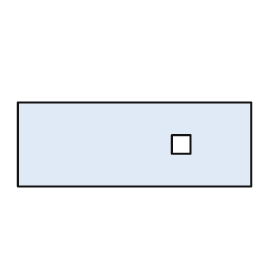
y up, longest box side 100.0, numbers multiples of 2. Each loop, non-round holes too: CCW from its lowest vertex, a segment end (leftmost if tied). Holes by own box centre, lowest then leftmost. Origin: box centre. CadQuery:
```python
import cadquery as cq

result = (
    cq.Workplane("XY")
    .moveTo(-50.0, -18.0)
    .lineTo(50.0, -18.0)
    .lineTo(50.0, 18.0)
    .lineTo(-50.0, 18.0)
    .close()
    .moveTo(16.0, -4.0)
    .lineTo(24.0, -4.0)
    .lineTo(24.0, 4.0)
    .lineTo(16.0, 4.0)
    .close()
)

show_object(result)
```